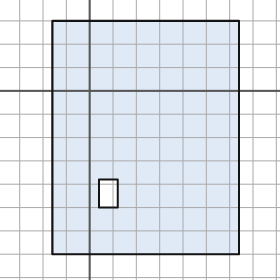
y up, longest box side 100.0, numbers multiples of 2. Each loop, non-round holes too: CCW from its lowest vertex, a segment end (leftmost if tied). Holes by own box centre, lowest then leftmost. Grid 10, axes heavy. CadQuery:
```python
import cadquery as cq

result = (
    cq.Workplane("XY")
    .moveTo(-16.0, -70.0)
    .lineTo(64.0, -70.0)
    .lineTo(64.0, 30.0)
    .lineTo(-16.0, 30.0)
    .close()
    .moveTo(4.0, -50.0)
    .lineTo(12.0, -50.0)
    .lineTo(12.0, -38.0)
    .lineTo(4.0, -38.0)
    .close()
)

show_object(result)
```